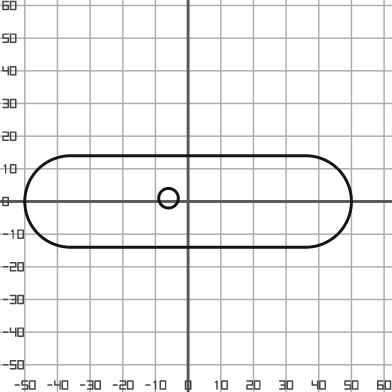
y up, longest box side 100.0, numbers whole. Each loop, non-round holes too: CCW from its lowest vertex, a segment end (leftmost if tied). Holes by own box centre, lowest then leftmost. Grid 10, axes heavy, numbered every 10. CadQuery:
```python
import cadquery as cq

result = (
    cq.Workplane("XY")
    .moveTo(-36.0, -14.0)
    .lineTo(36.0, -14.0)
    .threePointArc((50.0, 0.0), (36.0, 14.0))
    .lineTo(-36.0, 14.0)
    .threePointArc((-50.0, 0.0), (-36.0, -14.0))
    .close()
    .moveTo(-6.0, 1.0)
    .circle(3.0)
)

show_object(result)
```